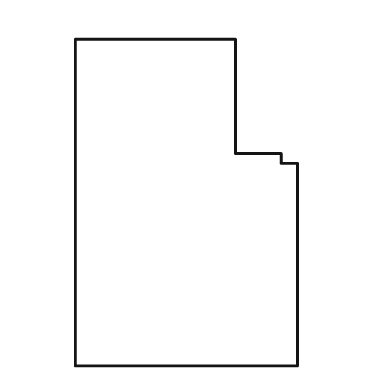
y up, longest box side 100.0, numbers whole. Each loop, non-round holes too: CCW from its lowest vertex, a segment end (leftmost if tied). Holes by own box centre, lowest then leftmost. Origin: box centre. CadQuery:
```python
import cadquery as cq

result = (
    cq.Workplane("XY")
    .moveTo(-34.0, -50.0)
    .lineTo(34.0, -50.0)
    .lineTo(34.0, 12.0)
    .lineTo(29.0, 12.0)
    .lineTo(29.0, 15.0)
    .lineTo(15.0, 15.0)
    .lineTo(15.0, 50.0)
    .lineTo(-34.0, 50.0)
    .close()
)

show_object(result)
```